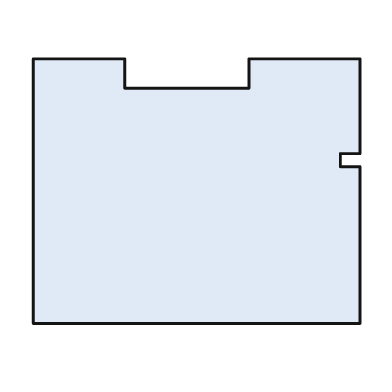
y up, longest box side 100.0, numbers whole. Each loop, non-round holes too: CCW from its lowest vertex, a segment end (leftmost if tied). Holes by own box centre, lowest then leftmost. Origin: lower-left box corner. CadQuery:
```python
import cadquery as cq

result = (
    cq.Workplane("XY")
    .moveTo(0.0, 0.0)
    .lineTo(100.0, 0.0)
    .lineTo(100.0, 48.0)
    .lineTo(94.0, 48.0)
    .lineTo(94.0, 52.0)
    .lineTo(100.0, 52.0)
    .lineTo(100.0, 81.0)
    .lineTo(66.0, 81.0)
    .lineTo(66.0, 72.0)
    .lineTo(28.0, 72.0)
    .lineTo(28.0, 81.0)
    .lineTo(0.0, 81.0)
    .close()
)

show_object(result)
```